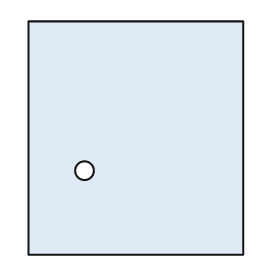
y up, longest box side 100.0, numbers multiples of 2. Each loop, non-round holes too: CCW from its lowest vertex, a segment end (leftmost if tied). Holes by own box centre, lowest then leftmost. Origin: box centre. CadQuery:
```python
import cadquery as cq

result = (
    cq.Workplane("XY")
    .moveTo(-46.0, -50.0)
    .lineTo(46.0, -50.0)
    .lineTo(46.0, 50.0)
    .lineTo(-46.0, 50.0)
    .close()
    .moveTo(-22.0, -14.0)
    .circle(4.0)
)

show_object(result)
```